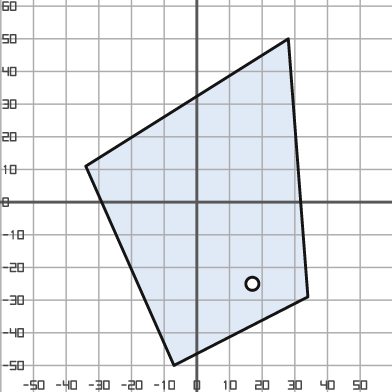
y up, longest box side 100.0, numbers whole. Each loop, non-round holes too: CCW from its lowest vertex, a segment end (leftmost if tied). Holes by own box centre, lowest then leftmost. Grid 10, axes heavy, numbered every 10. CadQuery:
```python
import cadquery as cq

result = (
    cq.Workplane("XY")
    .moveTo(-7.0, -50.0)
    .lineTo(34.0, -29.0)
    .lineTo(28.0, 50.0)
    .lineTo(-34.0, 11.0)
    .close()
    .moveTo(17.0, -25.0)
    .circle(2.0)
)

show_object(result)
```